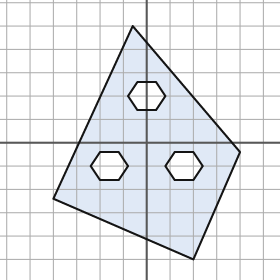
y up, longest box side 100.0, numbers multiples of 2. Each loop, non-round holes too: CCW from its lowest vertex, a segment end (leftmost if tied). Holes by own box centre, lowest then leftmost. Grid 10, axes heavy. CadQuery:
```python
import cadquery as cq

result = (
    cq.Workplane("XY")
    .moveTo(20.0, -50.0)
    .lineTo(40.0, -4.0)
    .lineTo(-6.0, 50.0)
    .lineTo(-40.0, -24.0)
    .close()
    .moveTo(-20.0, -16.0)
    .lineTo(-12.0, -16.0)
    .lineTo(-8.0, -10.0)
    .lineTo(-12.0, -4.0)
    .lineTo(-20.0, -4.0)
    .lineTo(-24.0, -10.0)
    .close()
    .moveTo(12.0, -16.0)
    .lineTo(20.0, -16.0)
    .lineTo(24.0, -10.0)
    .lineTo(20.0, -4.0)
    .lineTo(12.0, -4.0)
    .lineTo(8.0, -10.0)
    .close()
    .moveTo(-4.0, 14.0)
    .lineTo(4.0, 14.0)
    .lineTo(8.0, 20.0)
    .lineTo(4.0, 26.0)
    .lineTo(-4.0, 26.0)
    .lineTo(-8.0, 20.0)
    .close()
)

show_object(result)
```